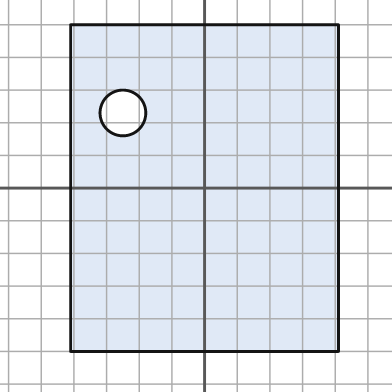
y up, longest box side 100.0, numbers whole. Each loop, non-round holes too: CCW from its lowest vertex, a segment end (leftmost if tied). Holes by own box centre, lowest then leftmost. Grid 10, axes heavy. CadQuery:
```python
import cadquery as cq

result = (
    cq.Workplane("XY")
    .moveTo(-41.0, -50.0)
    .lineTo(41.0, -50.0)
    .lineTo(41.0, 50.0)
    .lineTo(-41.0, 50.0)
    .close()
    .moveTo(-25.0, 23.0)
    .circle(7.0)
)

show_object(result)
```